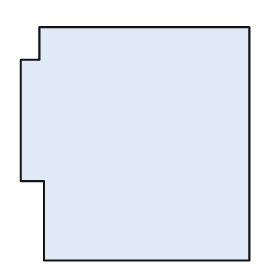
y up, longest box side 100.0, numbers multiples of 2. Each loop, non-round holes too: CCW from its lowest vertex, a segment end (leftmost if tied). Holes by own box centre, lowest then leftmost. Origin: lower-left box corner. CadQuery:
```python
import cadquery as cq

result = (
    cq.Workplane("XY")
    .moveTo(10.0, 0.0)
    .lineTo(98.0, 0.0)
    .lineTo(98.0, 100.0)
    .lineTo(8.0, 100.0)
    .lineTo(8.0, 86.0)
    .lineTo(0.0, 86.0)
    .lineTo(0.0, 34.0)
    .lineTo(10.0, 34.0)
    .close()
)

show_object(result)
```